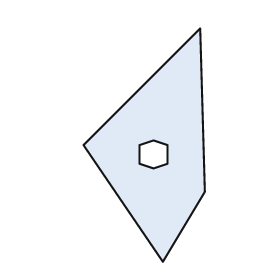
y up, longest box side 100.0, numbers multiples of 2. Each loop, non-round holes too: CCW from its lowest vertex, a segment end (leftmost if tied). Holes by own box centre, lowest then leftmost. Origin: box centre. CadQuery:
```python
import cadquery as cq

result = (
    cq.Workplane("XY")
    .moveTo(8.0, -50.0)
    .lineTo(26.0, -20.0)
    .lineTo(24.0, 50.0)
    .lineTo(-26.0, 0.0)
    .close()
    .moveTo(4.0, -10.0)
    .lineTo(10.0, -8.0)
    .lineTo(10.0, 0.0)
    .lineTo(4.0, 2.0)
    .lineTo(-2.0, 0.0)
    .lineTo(-2.0, -8.0)
    .close()
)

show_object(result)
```